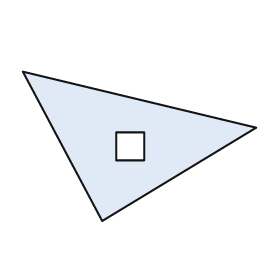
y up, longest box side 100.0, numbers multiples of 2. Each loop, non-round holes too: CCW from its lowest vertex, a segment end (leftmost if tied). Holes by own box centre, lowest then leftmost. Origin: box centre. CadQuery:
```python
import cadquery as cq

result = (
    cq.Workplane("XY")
    .moveTo(-16.0, -32.0)
    .lineTo(50.0, 8.0)
    .lineTo(-50.0, 32.0)
    .close()
    .moveTo(-10.0, -6.0)
    .lineTo(2.0, -6.0)
    .lineTo(2.0, 6.0)
    .lineTo(-10.0, 6.0)
    .close()
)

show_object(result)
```